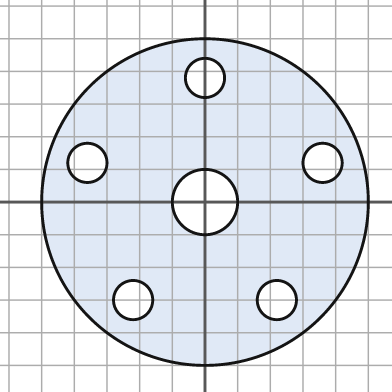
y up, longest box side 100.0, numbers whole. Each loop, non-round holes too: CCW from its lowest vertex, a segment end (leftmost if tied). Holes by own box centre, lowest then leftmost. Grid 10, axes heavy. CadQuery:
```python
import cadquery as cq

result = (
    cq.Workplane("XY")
    .moveTo(0.0, 0.0)
    .circle(50.0)
    .moveTo(-22.0, -30.0)
    .circle(6.0)
    .moveTo(22.0, -30.0)
    .circle(6.0)
    .moveTo(0.0, 0.0)
    .circle(10.0)
    .moveTo(-36.0, 12.0)
    .circle(6.0)
    .moveTo(36.0, 12.0)
    .circle(6.0)
    .moveTo(0.0, 38.0)
    .circle(6.0)
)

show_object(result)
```